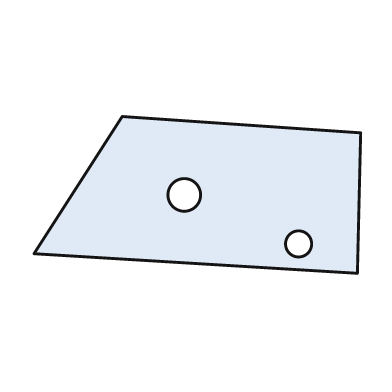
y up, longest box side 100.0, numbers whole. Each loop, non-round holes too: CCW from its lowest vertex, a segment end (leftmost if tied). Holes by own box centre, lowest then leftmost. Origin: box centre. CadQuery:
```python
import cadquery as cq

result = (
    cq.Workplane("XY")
    .moveTo(49.0, -24.0)
    .lineTo(50.0, 19.0)
    .lineTo(-23.0, 24.0)
    .lineTo(-50.0, -18.0)
    .close()
    .moveTo(31.0, -15.0)
    .circle(4.0)
    .moveTo(-4.0, 0.0)
    .circle(5.0)
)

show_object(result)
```